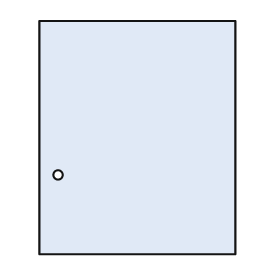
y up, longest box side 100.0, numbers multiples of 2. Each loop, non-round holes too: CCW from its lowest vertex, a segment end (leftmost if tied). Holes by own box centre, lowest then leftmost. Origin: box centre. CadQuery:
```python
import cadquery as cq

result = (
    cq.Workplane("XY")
    .moveTo(-42.0, -50.0)
    .lineTo(42.0, -50.0)
    .lineTo(42.0, 50.0)
    .lineTo(-42.0, 50.0)
    .close()
    .moveTo(-34.0, -16.0)
    .circle(2.0)
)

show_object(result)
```